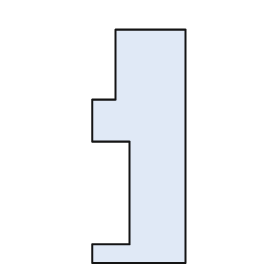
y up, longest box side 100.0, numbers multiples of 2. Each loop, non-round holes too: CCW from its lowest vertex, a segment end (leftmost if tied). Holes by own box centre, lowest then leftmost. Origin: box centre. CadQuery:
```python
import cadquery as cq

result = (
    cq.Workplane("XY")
    .moveTo(-20.0, -50.0)
    .lineTo(20.0, -50.0)
    .lineTo(20.0, 50.0)
    .lineTo(-10.0, 50.0)
    .lineTo(-10.0, 20.0)
    .lineTo(-20.0, 20.0)
    .lineTo(-20.0, 2.0)
    .lineTo(-4.0, 2.0)
    .lineTo(-4.0, -42.0)
    .lineTo(-20.0, -42.0)
    .close()
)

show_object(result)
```